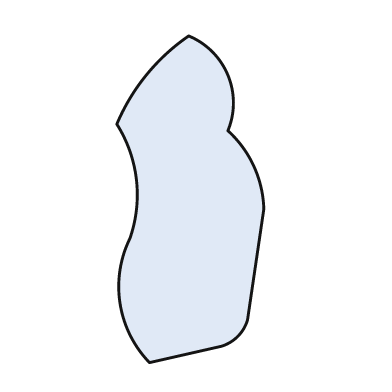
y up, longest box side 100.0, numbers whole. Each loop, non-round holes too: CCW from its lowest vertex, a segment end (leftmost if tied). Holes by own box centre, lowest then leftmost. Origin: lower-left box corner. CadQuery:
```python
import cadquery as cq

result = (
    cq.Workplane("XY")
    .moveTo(10.0, 0.0)
    .lineTo(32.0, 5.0)
    .threePointArc((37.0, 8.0), (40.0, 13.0))
    .lineTo(45.0, 47.0)
    .threePointArc((42.0, 60.0), (34.0, 71.0))
    .threePointArc((34.0, 88.0), (22.0, 100.0))
    .threePointArc((9.0, 88.0), (0.0, 73.0))
    .threePointArc((6.0, 56.0), (4.0, 38.0))
    .threePointArc((1.0, 18.0), (10.0, 0.0))
    .close()
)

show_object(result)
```